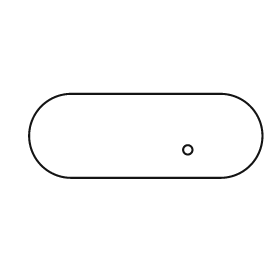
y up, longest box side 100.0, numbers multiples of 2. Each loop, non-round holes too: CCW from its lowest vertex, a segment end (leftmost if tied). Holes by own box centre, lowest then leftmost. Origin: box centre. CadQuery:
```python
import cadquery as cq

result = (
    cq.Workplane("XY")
    .moveTo(-32.0, -18.0)
    .lineTo(32.0, -18.0)
    .threePointArc((50.0, 0.0), (32.0, 18.0))
    .lineTo(-32.0, 18.0)
    .threePointArc((-50.0, 0.0), (-32.0, -18.0))
    .close()
    .moveTo(18.0, -6.0)
    .circle(2.0)
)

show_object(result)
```